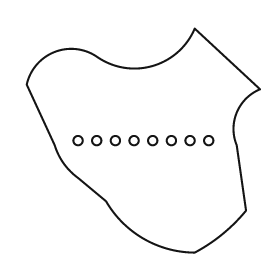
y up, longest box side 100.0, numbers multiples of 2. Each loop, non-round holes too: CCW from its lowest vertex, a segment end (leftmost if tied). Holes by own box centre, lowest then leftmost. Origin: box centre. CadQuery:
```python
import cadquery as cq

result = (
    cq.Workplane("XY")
    .moveTo(22.0, -48.0)
    .threePointArc((34.0, -40.0), (44.0, -30.0))
    .lineTo(40.0, -2.0)
    .threePointArc((40.0, 12.0), (50.0, 22.0))
    .lineTo(22.0, 48.0)
    .threePointArc((4.0, 32.0), (-20.0, 36.0))
    .threePointArc((-38.0, 38.0), (-50.0, 24.0))
    .lineTo(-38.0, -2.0)
    .threePointArc((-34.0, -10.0), (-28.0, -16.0))
    .lineTo(-16.0, -26.0)
    .threePointArc((0.0, -42.0), (22.0, -48.0))
    .close()
    .moveTo(-28.0, 0.0)
    .circle(2.0)
    .moveTo(-20.0, 0.0)
    .circle(2.0)
    .moveTo(-12.0, 0.0)
    .circle(2.0)
    .moveTo(-4.0, 0.0)
    .circle(2.0)
    .moveTo(4.0, 0.0)
    .circle(2.0)
    .moveTo(12.0, 0.0)
    .circle(2.0)
    .moveTo(20.0, 0.0)
    .circle(2.0)
    .moveTo(28.0, 0.0)
    .circle(2.0)
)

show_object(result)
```